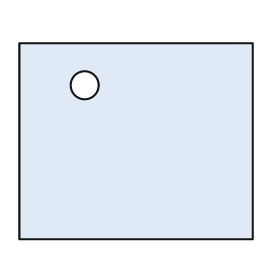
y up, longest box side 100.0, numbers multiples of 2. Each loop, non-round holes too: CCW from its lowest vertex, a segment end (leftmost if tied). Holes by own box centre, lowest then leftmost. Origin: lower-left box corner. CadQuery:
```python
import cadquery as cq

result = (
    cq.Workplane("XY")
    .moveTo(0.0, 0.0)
    .lineTo(100.0, 0.0)
    .lineTo(100.0, 84.0)
    .lineTo(0.0, 84.0)
    .close()
    .moveTo(28.0, 66.0)
    .circle(6.0)
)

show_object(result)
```